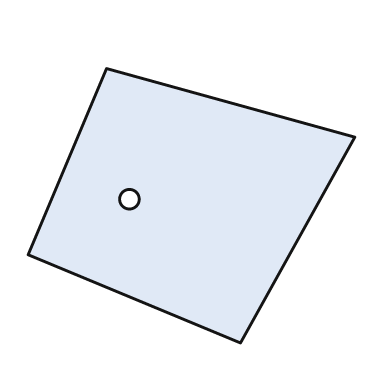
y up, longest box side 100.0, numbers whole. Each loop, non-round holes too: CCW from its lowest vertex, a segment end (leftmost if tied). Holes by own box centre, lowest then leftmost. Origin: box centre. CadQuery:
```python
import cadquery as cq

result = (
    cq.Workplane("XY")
    .moveTo(15.0, -42.0)
    .lineTo(50.0, 21.0)
    .lineTo(-26.0, 42.0)
    .lineTo(-50.0, -15.0)
    .close()
    .moveTo(-19.0, 2.0)
    .circle(3.0)
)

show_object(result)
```